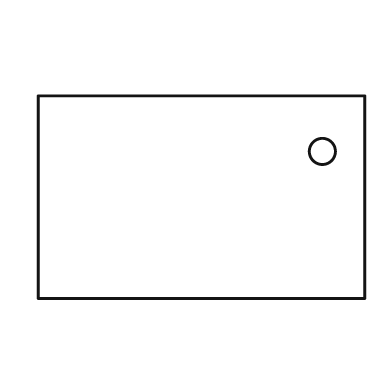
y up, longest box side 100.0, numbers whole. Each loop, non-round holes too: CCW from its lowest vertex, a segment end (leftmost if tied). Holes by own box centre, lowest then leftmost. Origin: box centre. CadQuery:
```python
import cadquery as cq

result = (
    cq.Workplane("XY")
    .moveTo(-50.0, -31.0)
    .lineTo(50.0, -31.0)
    .lineTo(50.0, 31.0)
    .lineTo(-50.0, 31.0)
    .close()
    .moveTo(37.0, 14.0)
    .circle(4.0)
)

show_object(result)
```